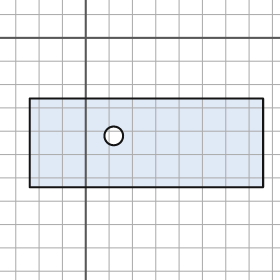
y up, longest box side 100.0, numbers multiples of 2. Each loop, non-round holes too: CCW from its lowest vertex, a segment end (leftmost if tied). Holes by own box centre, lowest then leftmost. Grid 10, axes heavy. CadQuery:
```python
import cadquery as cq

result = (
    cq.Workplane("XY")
    .moveTo(-24.0, -64.0)
    .lineTo(76.0, -64.0)
    .lineTo(76.0, -26.0)
    .lineTo(-24.0, -26.0)
    .close()
    .moveTo(12.0, -42.0)
    .circle(4.0)
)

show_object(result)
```